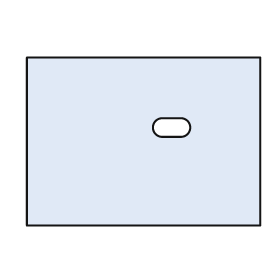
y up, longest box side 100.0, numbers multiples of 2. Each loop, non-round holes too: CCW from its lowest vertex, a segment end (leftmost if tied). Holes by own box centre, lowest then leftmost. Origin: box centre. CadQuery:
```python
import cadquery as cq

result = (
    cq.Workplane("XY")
    .moveTo(-50.0, -36.0)
    .lineTo(50.0, -36.0)
    .lineTo(50.0, 36.0)
    .lineTo(-50.0, 36.0)
    .close()
    .moveTo(8.0, 2.0)
    .lineTo(16.0, 2.0)
    .threePointArc((20.0, 6.0), (16.0, 10.0))
    .lineTo(8.0, 10.0)
    .threePointArc((4.0, 6.0), (8.0, 2.0))
    .close()
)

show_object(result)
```